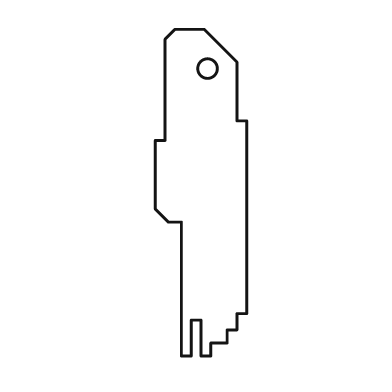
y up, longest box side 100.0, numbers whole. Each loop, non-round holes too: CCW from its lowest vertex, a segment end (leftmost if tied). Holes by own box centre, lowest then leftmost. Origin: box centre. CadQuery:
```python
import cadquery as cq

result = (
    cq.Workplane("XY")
    .moveTo(-6.0, -50.0)
    .lineTo(-3.0, -50.0)
    .lineTo(-3.0, -39.0)
    .lineTo(0.0, -39.0)
    .lineTo(0.0, -50.0)
    .lineTo(3.0, -50.0)
    .lineTo(3.0, -46.0)
    .lineTo(8.0, -46.0)
    .lineTo(8.0, -42.0)
    .lineTo(11.0, -42.0)
    .lineTo(11.0, -37.0)
    .lineTo(14.0, -37.0)
    .lineTo(14.0, 22.0)
    .lineTo(11.0, 22.0)
    .lineTo(11.0, 40.0)
    .lineTo(1.0, 50.0)
    .lineTo(-8.0, 50.0)
    .lineTo(-11.0, 47.0)
    .lineTo(-11.0, 16.0)
    .lineTo(-14.0, 16.0)
    .lineTo(-14.0, -5.0)
    .lineTo(-10.0, -9.0)
    .lineTo(-6.0, -9.0)
    .close()
    .moveTo(2.0, 38.0)
    .circle(3.0)
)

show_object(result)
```